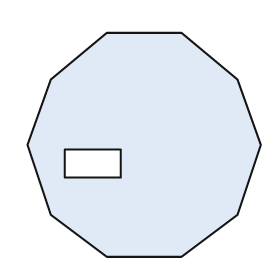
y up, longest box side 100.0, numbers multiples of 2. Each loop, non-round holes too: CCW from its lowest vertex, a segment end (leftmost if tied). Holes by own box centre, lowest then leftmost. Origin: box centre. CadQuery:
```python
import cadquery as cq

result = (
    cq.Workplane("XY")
    .moveTo(-16.0, -48.0)
    .lineTo(16.0, -48.0)
    .lineTo(40.0, -30.0)
    .lineTo(50.0, 0.0)
    .lineTo(40.0, 28.0)
    .lineTo(16.0, 48.0)
    .lineTo(-16.0, 48.0)
    .lineTo(-40.0, 28.0)
    .lineTo(-50.0, 0.0)
    .lineTo(-40.0, -30.0)
    .close()
    .moveTo(-34.0, -14.0)
    .lineTo(-10.0, -14.0)
    .lineTo(-10.0, -2.0)
    .lineTo(-34.0, -2.0)
    .close()
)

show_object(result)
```